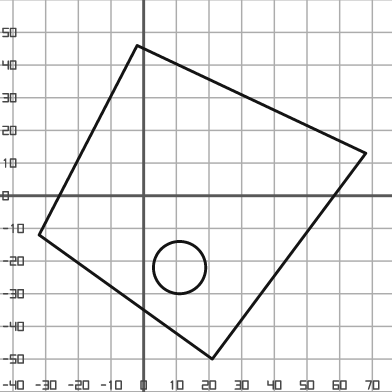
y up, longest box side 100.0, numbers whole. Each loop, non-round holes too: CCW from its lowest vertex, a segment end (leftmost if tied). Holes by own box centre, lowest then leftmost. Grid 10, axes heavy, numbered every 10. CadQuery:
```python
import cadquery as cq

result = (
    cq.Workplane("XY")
    .moveTo(21.0, -50.0)
    .lineTo(68.0, 13.0)
    .lineTo(-2.0, 46.0)
    .lineTo(-32.0, -12.0)
    .close()
    .moveTo(11.0, -22.0)
    .circle(8.0)
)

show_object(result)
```